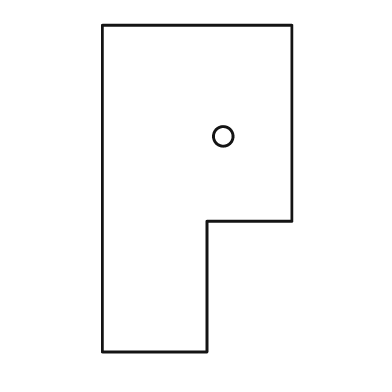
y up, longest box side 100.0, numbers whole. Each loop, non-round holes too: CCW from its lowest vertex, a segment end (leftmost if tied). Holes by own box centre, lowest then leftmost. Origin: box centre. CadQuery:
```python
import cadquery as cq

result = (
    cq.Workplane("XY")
    .moveTo(-29.0, -50.0)
    .lineTo(3.0, -50.0)
    .lineTo(3.0, -10.0)
    .lineTo(29.0, -10.0)
    .lineTo(29.0, 50.0)
    .lineTo(-29.0, 50.0)
    .close()
    .moveTo(8.0, 16.0)
    .circle(3.0)
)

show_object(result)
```